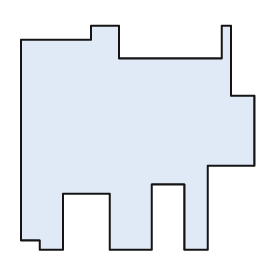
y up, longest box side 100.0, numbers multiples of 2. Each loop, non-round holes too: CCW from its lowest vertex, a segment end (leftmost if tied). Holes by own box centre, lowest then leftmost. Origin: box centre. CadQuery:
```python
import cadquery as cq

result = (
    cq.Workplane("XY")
    .moveTo(-42.0, -48.0)
    .lineTo(-32.0, -48.0)
    .lineTo(-32.0, -24.0)
    .lineTo(-12.0, -24.0)
    .lineTo(-12.0, -48.0)
    .lineTo(6.0, -48.0)
    .lineTo(6.0, -20.0)
    .lineTo(20.0, -20.0)
    .lineTo(20.0, -48.0)
    .lineTo(30.0, -48.0)
    .lineTo(30.0, -12.0)
    .lineTo(50.0, -12.0)
    .lineTo(50.0, 18.0)
    .lineTo(40.0, 18.0)
    .lineTo(40.0, 48.0)
    .lineTo(36.0, 48.0)
    .lineTo(36.0, 34.0)
    .lineTo(-8.0, 34.0)
    .lineTo(-8.0, 48.0)
    .lineTo(-20.0, 48.0)
    .lineTo(-20.0, 42.0)
    .lineTo(-50.0, 42.0)
    .lineTo(-50.0, -44.0)
    .lineTo(-42.0, -44.0)
    .close()
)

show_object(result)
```